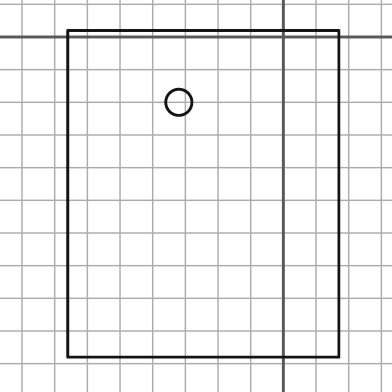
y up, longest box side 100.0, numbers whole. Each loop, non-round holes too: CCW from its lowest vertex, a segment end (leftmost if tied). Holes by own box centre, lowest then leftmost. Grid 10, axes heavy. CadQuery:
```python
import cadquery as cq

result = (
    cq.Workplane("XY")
    .moveTo(-66.0, -98.0)
    .lineTo(17.0, -98.0)
    .lineTo(17.0, 2.0)
    .lineTo(-66.0, 2.0)
    .close()
    .moveTo(-32.0, -20.0)
    .circle(4.0)
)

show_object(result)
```